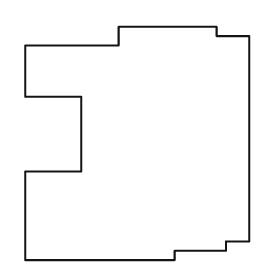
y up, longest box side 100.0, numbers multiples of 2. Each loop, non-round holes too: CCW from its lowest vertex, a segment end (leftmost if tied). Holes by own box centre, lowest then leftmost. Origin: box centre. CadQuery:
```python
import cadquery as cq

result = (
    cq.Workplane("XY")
    .moveTo(-48.0, -50.0)
    .lineTo(16.0, -50.0)
    .lineTo(16.0, -46.0)
    .lineTo(38.0, -46.0)
    .lineTo(38.0, -42.0)
    .lineTo(48.0, -42.0)
    .lineTo(48.0, 46.0)
    .lineTo(34.0, 46.0)
    .lineTo(34.0, 50.0)
    .lineTo(-8.0, 50.0)
    .lineTo(-8.0, 42.0)
    .lineTo(-48.0, 42.0)
    .lineTo(-48.0, 20.0)
    .lineTo(-24.0, 20.0)
    .lineTo(-24.0, -12.0)
    .lineTo(-48.0, -12.0)
    .close()
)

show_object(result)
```